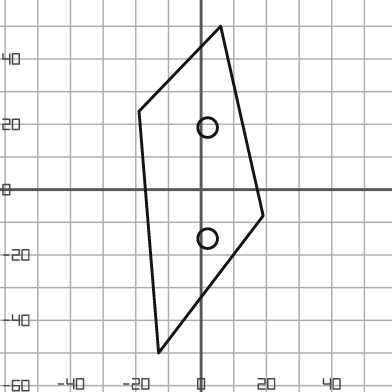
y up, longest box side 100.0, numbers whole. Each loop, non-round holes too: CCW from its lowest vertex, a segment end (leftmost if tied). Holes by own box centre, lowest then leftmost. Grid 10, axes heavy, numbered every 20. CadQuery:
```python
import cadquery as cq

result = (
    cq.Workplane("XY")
    .moveTo(-13.0, -50.0)
    .lineTo(19.0, -8.0)
    .lineTo(6.0, 50.0)
    .lineTo(-19.0, 24.0)
    .close()
    .moveTo(2.0, -15.0)
    .circle(3.0)
    .moveTo(2.0, 19.0)
    .circle(3.0)
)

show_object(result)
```